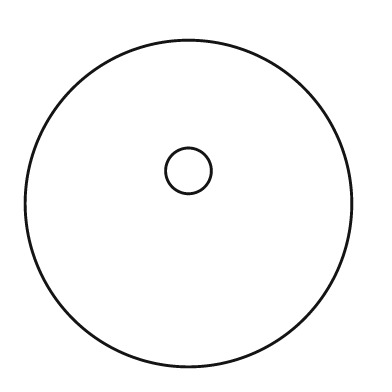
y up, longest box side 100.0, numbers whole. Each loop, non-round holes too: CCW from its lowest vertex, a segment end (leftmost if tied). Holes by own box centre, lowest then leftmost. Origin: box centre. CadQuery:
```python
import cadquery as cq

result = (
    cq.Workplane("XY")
    .moveTo(0.0, 0.0)
    .circle(50.0)
    .moveTo(0.0, 10.0)
    .circle(7.0)
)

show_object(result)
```